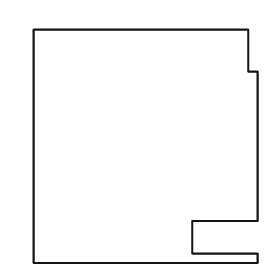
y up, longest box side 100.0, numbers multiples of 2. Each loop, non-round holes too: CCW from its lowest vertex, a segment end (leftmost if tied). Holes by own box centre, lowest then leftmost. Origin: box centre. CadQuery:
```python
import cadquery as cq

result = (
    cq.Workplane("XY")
    .moveTo(-48.0, -50.0)
    .lineTo(48.0, -50.0)
    .lineTo(48.0, -46.0)
    .lineTo(20.0, -46.0)
    .lineTo(20.0, -32.0)
    .lineTo(48.0, -32.0)
    .lineTo(48.0, 32.0)
    .lineTo(44.0, 32.0)
    .lineTo(44.0, 50.0)
    .lineTo(-48.0, 50.0)
    .close()
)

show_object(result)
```